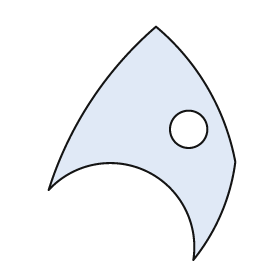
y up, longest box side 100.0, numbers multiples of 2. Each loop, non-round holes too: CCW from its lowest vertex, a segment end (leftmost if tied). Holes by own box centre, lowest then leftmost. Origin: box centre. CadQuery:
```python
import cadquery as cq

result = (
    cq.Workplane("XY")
    .moveTo(22.0, -50.0)
    .threePointArc((34.0, -30.0), (40.0, -8.0))
    .threePointArc((28.0, 24.0), (6.0, 50.0))
    .threePointArc((-22.0, 18.0), (-40.0, -20.0))
    .threePointArc((2.0, -12.0), (22.0, -50.0))
    .close()
    .moveTo(20.0, 6.0)
    .circle(8.0)
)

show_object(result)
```